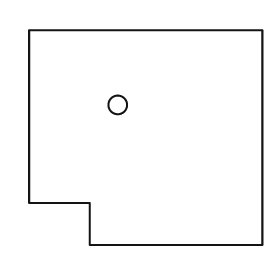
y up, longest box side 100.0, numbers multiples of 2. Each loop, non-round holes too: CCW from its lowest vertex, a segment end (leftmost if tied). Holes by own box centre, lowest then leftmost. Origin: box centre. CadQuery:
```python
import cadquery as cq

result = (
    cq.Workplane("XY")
    .moveTo(-24.0, -46.0)
    .lineTo(50.0, -46.0)
    .lineTo(50.0, 46.0)
    .lineTo(-50.0, 46.0)
    .lineTo(-50.0, -28.0)
    .lineTo(-24.0, -28.0)
    .close()
    .moveTo(-12.0, 14.0)
    .circle(4.0)
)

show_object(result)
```